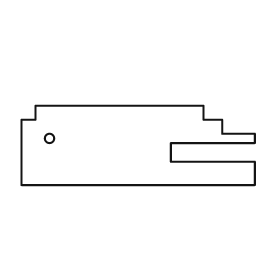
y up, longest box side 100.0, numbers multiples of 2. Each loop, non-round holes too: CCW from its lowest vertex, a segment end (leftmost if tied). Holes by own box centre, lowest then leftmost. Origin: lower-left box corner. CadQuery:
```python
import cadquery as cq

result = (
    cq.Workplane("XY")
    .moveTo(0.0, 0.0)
    .lineTo(100.0, 0.0)
    .lineTo(100.0, 10.0)
    .lineTo(64.0, 10.0)
    .lineTo(64.0, 18.0)
    .lineTo(100.0, 18.0)
    .lineTo(100.0, 22.0)
    .lineTo(86.0, 22.0)
    .lineTo(86.0, 28.0)
    .lineTo(78.0, 28.0)
    .lineTo(78.0, 34.0)
    .lineTo(6.0, 34.0)
    .lineTo(6.0, 28.0)
    .lineTo(0.0, 28.0)
    .close()
    .moveTo(12.0, 20.0)
    .circle(2.0)
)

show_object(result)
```